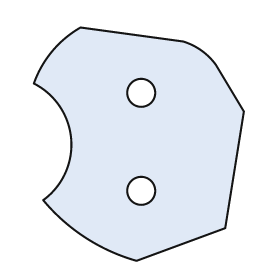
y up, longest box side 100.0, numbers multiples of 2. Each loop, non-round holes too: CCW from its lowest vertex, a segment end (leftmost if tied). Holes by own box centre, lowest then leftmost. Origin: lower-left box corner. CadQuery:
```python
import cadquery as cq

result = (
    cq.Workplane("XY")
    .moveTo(44.0, 0.0)
    .lineTo(82.0, 14.0)
    .lineTo(90.0, 64.0)
    .lineTo(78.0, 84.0)
    .threePointArc((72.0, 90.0), (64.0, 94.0))
    .lineTo(20.0, 100.0)
    .threePointArc((8.0, 90.0), (0.0, 76.0))
    .threePointArc((16.0, 52.0), (4.0, 26.0))
    .threePointArc((22.0, 10.0), (44.0, 0.0))
    .close()
    .moveTo(46.0, 30.0)
    .circle(6.0)
    .moveTo(46.0, 72.0)
    .circle(6.0)
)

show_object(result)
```